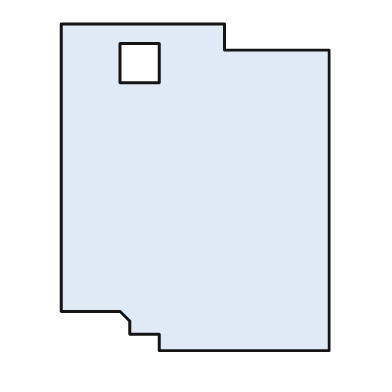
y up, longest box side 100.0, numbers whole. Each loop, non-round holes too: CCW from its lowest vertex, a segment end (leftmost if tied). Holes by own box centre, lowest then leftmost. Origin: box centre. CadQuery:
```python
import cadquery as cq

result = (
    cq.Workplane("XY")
    .moveTo(-11.0, -50.0)
    .lineTo(41.0, -50.0)
    .lineTo(41.0, 42.0)
    .lineTo(9.0, 42.0)
    .lineTo(9.0, 50.0)
    .lineTo(-41.0, 50.0)
    .lineTo(-41.0, -38.0)
    .lineTo(-23.0, -38.0)
    .lineTo(-20.0, -41.0)
    .lineTo(-20.0, -45.0)
    .lineTo(-11.0, -45.0)
    .close()
    .moveTo(-23.0, 32.0)
    .lineTo(-11.0, 32.0)
    .lineTo(-11.0, 44.0)
    .lineTo(-23.0, 44.0)
    .close()
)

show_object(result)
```